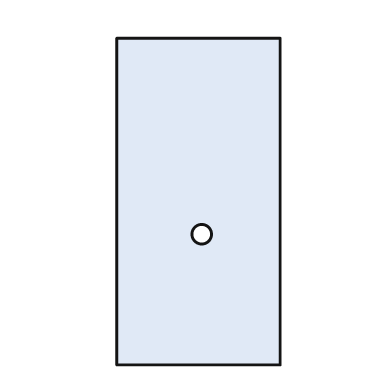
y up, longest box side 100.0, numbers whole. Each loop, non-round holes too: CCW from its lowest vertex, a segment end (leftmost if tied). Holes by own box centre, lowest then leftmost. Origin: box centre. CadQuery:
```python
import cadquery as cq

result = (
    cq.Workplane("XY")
    .moveTo(-25.0, -50.0)
    .lineTo(25.0, -50.0)
    .lineTo(25.0, 50.0)
    .lineTo(-25.0, 50.0)
    .close()
    .moveTo(1.0, -10.0)
    .circle(3.0)
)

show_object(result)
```